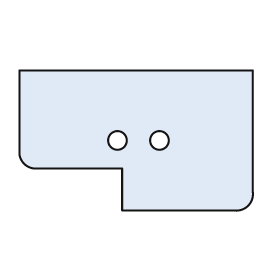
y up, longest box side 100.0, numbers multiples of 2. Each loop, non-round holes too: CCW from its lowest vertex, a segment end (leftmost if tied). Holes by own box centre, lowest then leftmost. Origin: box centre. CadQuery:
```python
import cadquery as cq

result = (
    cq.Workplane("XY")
    .moveTo(-6.0, -30.0)
    .lineTo(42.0, -30.0)
    .threePointArc((48.0, -28.0), (50.0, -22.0))
    .lineTo(50.0, 30.0)
    .lineTo(-50.0, 30.0)
    .lineTo(-50.0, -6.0)
    .threePointArc((-48.0, -10.0), (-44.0, -12.0))
    .lineTo(-6.0, -12.0)
    .close()
    .moveTo(-8.0, 0.0)
    .circle(4.0)
    .moveTo(10.0, 0.0)
    .circle(4.0)
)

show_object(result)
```